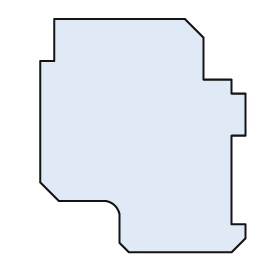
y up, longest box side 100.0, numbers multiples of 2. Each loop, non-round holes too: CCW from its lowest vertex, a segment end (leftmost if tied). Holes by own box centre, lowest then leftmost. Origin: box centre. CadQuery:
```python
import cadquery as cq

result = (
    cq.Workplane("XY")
    .moveTo(-6.0, -50.0)
    .lineTo(38.0, -50.0)
    .lineTo(44.0, -44.0)
    .lineTo(44.0, -38.0)
    .lineTo(38.0, -38.0)
    .lineTo(38.0, 0.0)
    .lineTo(44.0, 0.0)
    .lineTo(44.0, 18.0)
    .lineTo(38.0, 18.0)
    .lineTo(38.0, 24.0)
    .lineTo(26.0, 24.0)
    .lineTo(26.0, 42.0)
    .lineTo(18.0, 50.0)
    .lineTo(-38.0, 50.0)
    .lineTo(-38.0, 32.0)
    .lineTo(-44.0, 32.0)
    .lineTo(-44.0, -20.0)
    .lineTo(-36.0, -28.0)
    .lineTo(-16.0, -28.0)
    .threePointArc((-12.0, -30.0), (-10.0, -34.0))
    .lineTo(-10.0, -46.0)
    .close()
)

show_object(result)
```